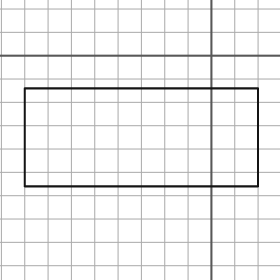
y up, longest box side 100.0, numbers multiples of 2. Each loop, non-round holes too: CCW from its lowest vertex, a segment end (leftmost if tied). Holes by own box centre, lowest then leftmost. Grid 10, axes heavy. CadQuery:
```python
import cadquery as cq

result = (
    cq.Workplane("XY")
    .moveTo(-80.0, -56.0)
    .lineTo(20.0, -56.0)
    .lineTo(20.0, -14.0)
    .lineTo(-80.0, -14.0)
    .close()
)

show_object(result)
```